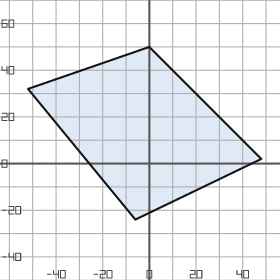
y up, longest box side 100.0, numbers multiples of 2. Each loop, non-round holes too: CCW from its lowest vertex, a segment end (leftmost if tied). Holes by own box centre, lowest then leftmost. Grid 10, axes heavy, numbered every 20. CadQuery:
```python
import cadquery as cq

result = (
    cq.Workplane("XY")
    .moveTo(-6.0, -24.0)
    .lineTo(48.0, 2.0)
    .lineTo(0.0, 50.0)
    .lineTo(-52.0, 32.0)
    .close()
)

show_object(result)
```